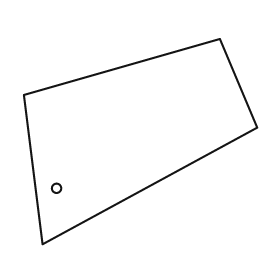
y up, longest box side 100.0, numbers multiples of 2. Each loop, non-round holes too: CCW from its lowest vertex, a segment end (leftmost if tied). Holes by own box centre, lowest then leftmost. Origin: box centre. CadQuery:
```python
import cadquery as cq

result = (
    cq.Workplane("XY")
    .moveTo(-42.0, -44.0)
    .lineTo(50.0, 6.0)
    .lineTo(34.0, 44.0)
    .lineTo(-50.0, 20.0)
    .close()
    .moveTo(-36.0, -20.0)
    .circle(2.0)
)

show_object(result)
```